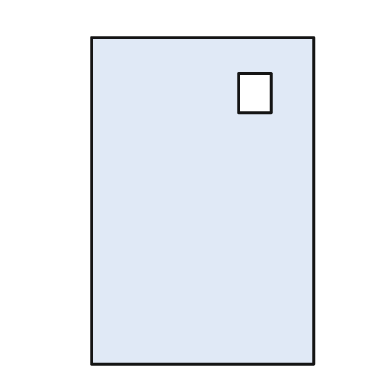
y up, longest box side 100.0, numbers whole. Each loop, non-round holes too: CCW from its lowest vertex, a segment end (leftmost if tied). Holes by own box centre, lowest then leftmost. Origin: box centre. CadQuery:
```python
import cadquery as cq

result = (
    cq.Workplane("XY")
    .moveTo(-34.0, -50.0)
    .lineTo(34.0, -50.0)
    .lineTo(34.0, 50.0)
    .lineTo(-34.0, 50.0)
    .close()
    .moveTo(11.0, 27.0)
    .lineTo(21.0, 27.0)
    .lineTo(21.0, 39.0)
    .lineTo(11.0, 39.0)
    .close()
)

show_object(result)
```